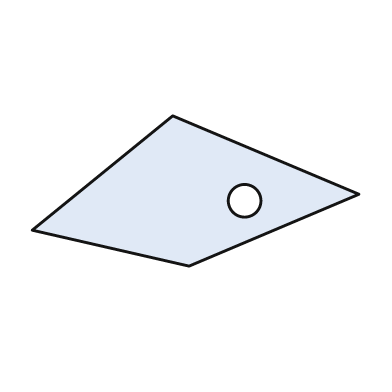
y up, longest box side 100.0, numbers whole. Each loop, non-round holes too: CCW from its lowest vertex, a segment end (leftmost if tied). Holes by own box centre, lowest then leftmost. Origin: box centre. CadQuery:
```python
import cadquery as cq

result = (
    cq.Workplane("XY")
    .moveTo(-2.0, -23.0)
    .lineTo(50.0, -1.0)
    .lineTo(-7.0, 23.0)
    .lineTo(-50.0, -12.0)
    .close()
    .moveTo(15.0, -3.0)
    .circle(5.0)
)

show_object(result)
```